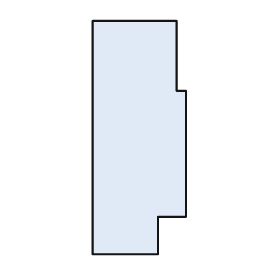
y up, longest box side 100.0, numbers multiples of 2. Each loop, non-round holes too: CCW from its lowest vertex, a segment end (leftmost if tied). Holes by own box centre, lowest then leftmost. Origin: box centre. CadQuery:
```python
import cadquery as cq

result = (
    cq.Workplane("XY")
    .moveTo(-20.0, -50.0)
    .lineTo(8.0, -50.0)
    .lineTo(8.0, -34.0)
    .lineTo(20.0, -34.0)
    .lineTo(20.0, 20.0)
    .lineTo(16.0, 20.0)
    .lineTo(16.0, 50.0)
    .lineTo(-20.0, 50.0)
    .close()
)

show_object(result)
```